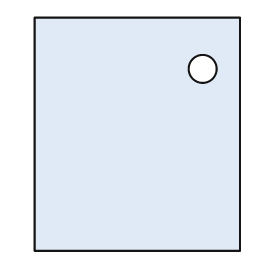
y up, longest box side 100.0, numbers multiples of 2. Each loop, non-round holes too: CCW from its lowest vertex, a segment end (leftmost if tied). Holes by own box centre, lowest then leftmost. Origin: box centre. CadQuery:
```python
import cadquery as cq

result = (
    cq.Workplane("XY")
    .moveTo(-44.0, -50.0)
    .lineTo(44.0, -50.0)
    .lineTo(44.0, 50.0)
    .lineTo(-44.0, 50.0)
    .close()
    .moveTo(28.0, 28.0)
    .circle(6.0)
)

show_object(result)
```